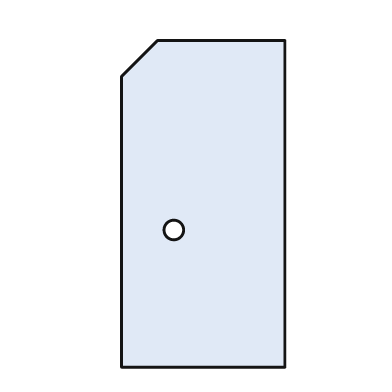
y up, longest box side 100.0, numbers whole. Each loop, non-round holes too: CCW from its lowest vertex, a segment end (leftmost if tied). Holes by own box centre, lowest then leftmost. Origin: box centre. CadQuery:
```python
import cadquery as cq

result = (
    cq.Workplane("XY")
    .moveTo(-25.0, -50.0)
    .lineTo(25.0, -50.0)
    .lineTo(25.0, 50.0)
    .lineTo(-14.0, 50.0)
    .lineTo(-25.0, 39.0)
    .close()
    .moveTo(-9.0, -8.0)
    .circle(3.0)
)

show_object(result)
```